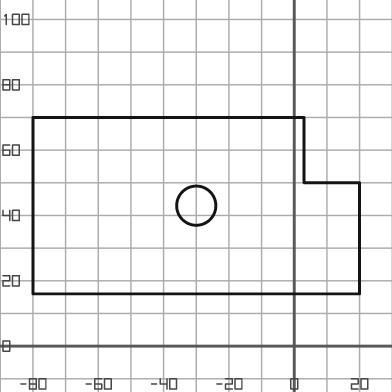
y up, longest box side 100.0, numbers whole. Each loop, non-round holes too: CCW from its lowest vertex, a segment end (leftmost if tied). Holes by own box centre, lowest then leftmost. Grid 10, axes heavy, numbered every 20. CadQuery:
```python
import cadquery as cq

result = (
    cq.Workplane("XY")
    .moveTo(-80.0, 16.0)
    .lineTo(20.0, 16.0)
    .lineTo(20.0, 50.0)
    .lineTo(3.0, 50.0)
    .lineTo(3.0, 70.0)
    .lineTo(-80.0, 70.0)
    .close()
    .moveTo(-30.0, 43.0)
    .circle(6.0)
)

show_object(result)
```